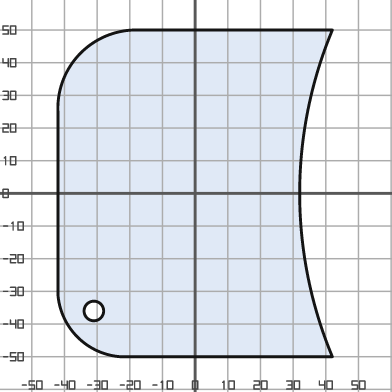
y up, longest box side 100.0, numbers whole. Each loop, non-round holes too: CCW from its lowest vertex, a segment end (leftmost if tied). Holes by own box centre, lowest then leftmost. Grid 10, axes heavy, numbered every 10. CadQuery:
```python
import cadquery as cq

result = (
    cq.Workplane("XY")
    .moveTo(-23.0, -50.0)
    .lineTo(42.0, -50.0)
    .threePointArc((32.0, 0.0), (42.0, 50.0))
    .lineTo(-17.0, 50.0)
    .threePointArc((-35.0, 43.0), (-42.0, 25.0))
    .lineTo(-42.0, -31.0)
    .threePointArc((-36.0, -44.0), (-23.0, -50.0))
    .close()
    .moveTo(-31.0, -36.0)
    .circle(3.0)
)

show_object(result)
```